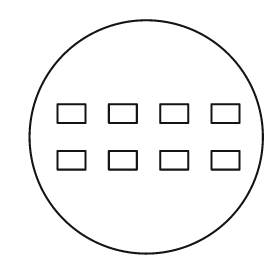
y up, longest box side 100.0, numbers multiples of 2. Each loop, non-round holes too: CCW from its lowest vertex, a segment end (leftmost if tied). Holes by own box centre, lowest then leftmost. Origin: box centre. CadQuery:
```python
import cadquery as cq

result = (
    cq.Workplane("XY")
    .moveTo(0.0, 0.0)
    .circle(50.0)
    .moveTo(-38.0, -14.0)
    .lineTo(-26.0, -14.0)
    .lineTo(-26.0, -6.0)
    .lineTo(-38.0, -6.0)
    .close()
    .moveTo(-16.0, -14.0)
    .lineTo(-4.0, -14.0)
    .lineTo(-4.0, -6.0)
    .lineTo(-16.0, -6.0)
    .close()
    .moveTo(6.0, -14.0)
    .lineTo(18.0, -14.0)
    .lineTo(18.0, -6.0)
    .lineTo(6.0, -6.0)
    .close()
    .moveTo(28.0, -14.0)
    .lineTo(40.0, -14.0)
    .lineTo(40.0, -6.0)
    .lineTo(28.0, -6.0)
    .close()
    .moveTo(-38.0, 6.0)
    .lineTo(-26.0, 6.0)
    .lineTo(-26.0, 14.0)
    .lineTo(-38.0, 14.0)
    .close()
    .moveTo(-16.0, 6.0)
    .lineTo(-4.0, 6.0)
    .lineTo(-4.0, 14.0)
    .lineTo(-16.0, 14.0)
    .close()
    .moveTo(6.0, 6.0)
    .lineTo(18.0, 6.0)
    .lineTo(18.0, 14.0)
    .lineTo(6.0, 14.0)
    .close()
    .moveTo(28.0, 6.0)
    .lineTo(40.0, 6.0)
    .lineTo(40.0, 14.0)
    .lineTo(28.0, 14.0)
    .close()
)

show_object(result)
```